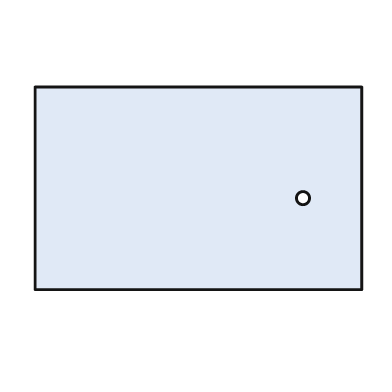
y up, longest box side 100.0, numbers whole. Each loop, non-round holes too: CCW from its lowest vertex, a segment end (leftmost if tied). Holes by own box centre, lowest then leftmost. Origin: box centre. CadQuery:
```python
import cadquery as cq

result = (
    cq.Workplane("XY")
    .moveTo(-50.0, -31.0)
    .lineTo(50.0, -31.0)
    .lineTo(50.0, 31.0)
    .lineTo(-50.0, 31.0)
    .close()
    .moveTo(32.0, -3.0)
    .circle(2.0)
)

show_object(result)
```